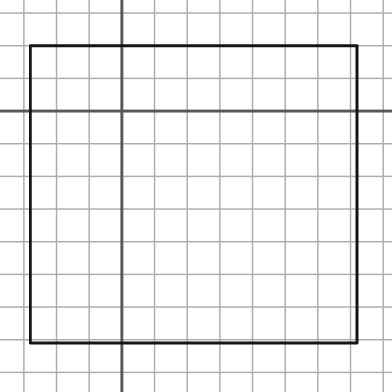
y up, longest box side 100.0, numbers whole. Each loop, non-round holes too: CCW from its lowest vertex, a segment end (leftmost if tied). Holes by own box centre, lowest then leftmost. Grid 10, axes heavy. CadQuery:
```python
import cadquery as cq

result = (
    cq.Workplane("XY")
    .moveTo(-28.0, -71.0)
    .lineTo(72.0, -71.0)
    .lineTo(72.0, 20.0)
    .lineTo(-28.0, 20.0)
    .close()
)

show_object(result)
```